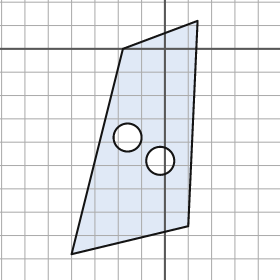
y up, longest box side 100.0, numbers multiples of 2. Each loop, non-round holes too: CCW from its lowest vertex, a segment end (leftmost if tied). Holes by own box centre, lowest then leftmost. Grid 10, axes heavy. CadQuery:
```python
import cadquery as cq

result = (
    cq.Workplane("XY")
    .moveTo(-40.0, -88.0)
    .lineTo(10.0, -76.0)
    .lineTo(14.0, 12.0)
    .lineTo(-18.0, 0.0)
    .close()
    .moveTo(-2.0, -48.0)
    .circle(6.0)
    .moveTo(-16.0, -38.0)
    .circle(6.0)
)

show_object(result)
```